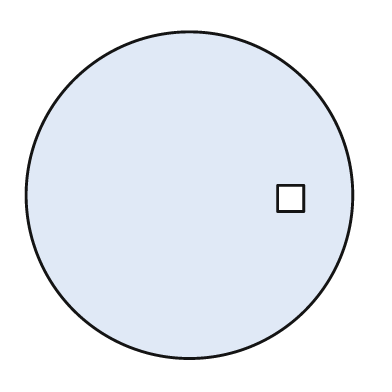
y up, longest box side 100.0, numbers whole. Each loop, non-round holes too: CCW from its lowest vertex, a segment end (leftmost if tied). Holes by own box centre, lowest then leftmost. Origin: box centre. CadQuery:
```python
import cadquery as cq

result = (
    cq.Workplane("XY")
    .moveTo(0.0, 0.0)
    .circle(50.0)
    .moveTo(27.0, -5.0)
    .lineTo(35.0, -5.0)
    .lineTo(35.0, 3.0)
    .lineTo(27.0, 3.0)
    .close()
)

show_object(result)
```